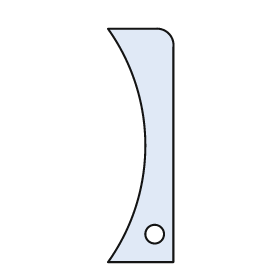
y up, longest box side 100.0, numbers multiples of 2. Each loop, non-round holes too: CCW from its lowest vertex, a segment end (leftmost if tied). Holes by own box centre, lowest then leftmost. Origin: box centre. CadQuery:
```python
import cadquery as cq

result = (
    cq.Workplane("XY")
    .moveTo(-14.0, -50.0)
    .lineTo(14.0, -50.0)
    .lineTo(14.0, 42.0)
    .threePointArc((12.0, 48.0), (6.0, 50.0))
    .lineTo(-14.0, 50.0)
    .threePointArc((2.0, 0.0), (-14.0, -50.0))
    .close()
    .moveTo(6.0, -38.0)
    .circle(4.0)
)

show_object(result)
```